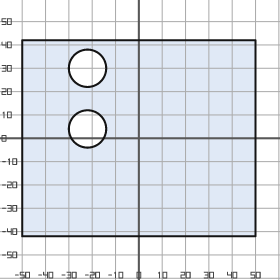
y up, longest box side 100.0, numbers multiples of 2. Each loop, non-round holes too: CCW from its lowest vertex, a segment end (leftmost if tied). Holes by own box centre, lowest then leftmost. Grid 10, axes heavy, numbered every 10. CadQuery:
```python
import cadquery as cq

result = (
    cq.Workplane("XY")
    .moveTo(-50.0, -42.0)
    .lineTo(50.0, -42.0)
    .lineTo(50.0, 42.0)
    .lineTo(-50.0, 42.0)
    .close()
    .moveTo(-22.0, 4.0)
    .circle(8.0)
    .moveTo(-22.0, 30.0)
    .circle(8.0)
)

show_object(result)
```